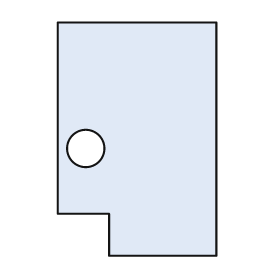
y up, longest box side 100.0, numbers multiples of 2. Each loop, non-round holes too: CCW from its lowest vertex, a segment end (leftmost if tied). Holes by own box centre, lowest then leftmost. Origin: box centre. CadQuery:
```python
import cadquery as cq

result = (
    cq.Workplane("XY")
    .moveTo(-12.0, -50.0)
    .lineTo(34.0, -50.0)
    .lineTo(34.0, 50.0)
    .lineTo(-34.0, 50.0)
    .lineTo(-34.0, -32.0)
    .lineTo(-12.0, -32.0)
    .close()
    .moveTo(-22.0, -4.0)
    .circle(8.0)
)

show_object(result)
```